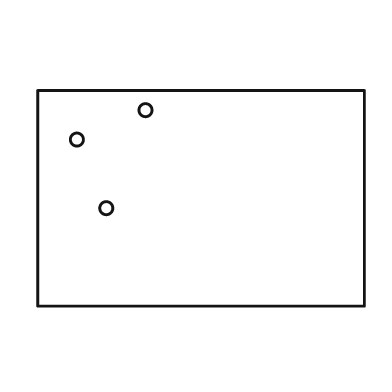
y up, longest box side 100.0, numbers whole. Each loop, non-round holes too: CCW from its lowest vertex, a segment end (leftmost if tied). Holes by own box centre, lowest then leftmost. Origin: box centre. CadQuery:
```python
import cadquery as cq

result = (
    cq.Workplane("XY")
    .moveTo(-50.0, -33.0)
    .lineTo(50.0, -33.0)
    .lineTo(50.0, 33.0)
    .lineTo(-50.0, 33.0)
    .close()
    .moveTo(-29.0, -3.0)
    .circle(2.0)
    .moveTo(-38.0, 18.0)
    .circle(2.0)
    .moveTo(-17.0, 27.0)
    .circle(2.0)
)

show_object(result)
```